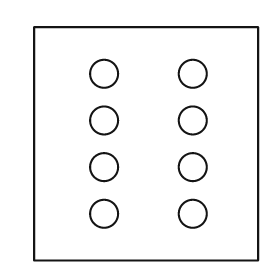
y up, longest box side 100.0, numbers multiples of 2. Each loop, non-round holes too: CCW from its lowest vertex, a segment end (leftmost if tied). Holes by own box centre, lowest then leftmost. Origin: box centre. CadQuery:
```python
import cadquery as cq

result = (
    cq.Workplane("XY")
    .moveTo(-48.0, -50.0)
    .lineTo(48.0, -50.0)
    .lineTo(48.0, 50.0)
    .lineTo(-48.0, 50.0)
    .close()
    .moveTo(-18.0, -30.0)
    .circle(6.0)
    .moveTo(20.0, -30.0)
    .circle(6.0)
    .moveTo(-18.0, -10.0)
    .circle(6.0)
    .moveTo(20.0, -10.0)
    .circle(6.0)
    .moveTo(-18.0, 10.0)
    .circle(6.0)
    .moveTo(20.0, 10.0)
    .circle(6.0)
    .moveTo(-18.0, 30.0)
    .circle(6.0)
    .moveTo(20.0, 30.0)
    .circle(6.0)
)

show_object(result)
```